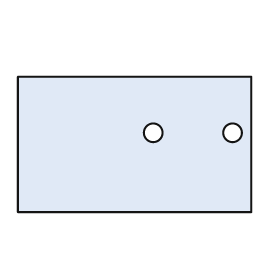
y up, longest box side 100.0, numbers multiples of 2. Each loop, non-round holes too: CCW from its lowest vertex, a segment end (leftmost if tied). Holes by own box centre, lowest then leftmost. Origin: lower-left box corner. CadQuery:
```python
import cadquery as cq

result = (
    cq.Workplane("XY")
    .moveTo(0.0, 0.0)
    .lineTo(100.0, 0.0)
    .lineTo(100.0, 58.0)
    .lineTo(0.0, 58.0)
    .close()
    .moveTo(58.0, 34.0)
    .circle(4.0)
    .moveTo(92.0, 34.0)
    .circle(4.0)
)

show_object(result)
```